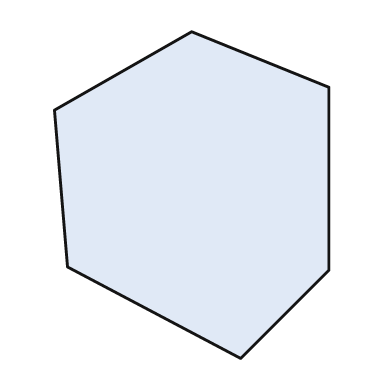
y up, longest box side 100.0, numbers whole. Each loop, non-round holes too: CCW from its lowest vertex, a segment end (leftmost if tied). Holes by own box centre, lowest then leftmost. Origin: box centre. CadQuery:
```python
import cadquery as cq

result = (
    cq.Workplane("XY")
    .moveTo(15.0, -50.0)
    .lineTo(42.0, -23.0)
    .lineTo(42.0, 33.0)
    .lineTo(0.0, 50.0)
    .lineTo(-42.0, 26.0)
    .lineTo(-38.0, -22.0)
    .close()
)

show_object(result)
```